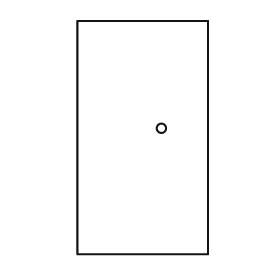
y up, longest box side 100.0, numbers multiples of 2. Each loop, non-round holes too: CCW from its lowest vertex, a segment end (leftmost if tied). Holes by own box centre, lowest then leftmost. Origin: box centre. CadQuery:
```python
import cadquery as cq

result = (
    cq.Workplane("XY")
    .moveTo(-28.0, -50.0)
    .lineTo(28.0, -50.0)
    .lineTo(28.0, 50.0)
    .lineTo(-28.0, 50.0)
    .close()
    .moveTo(8.0, 4.0)
    .circle(2.0)
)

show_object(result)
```